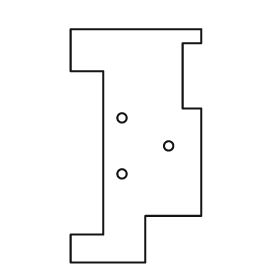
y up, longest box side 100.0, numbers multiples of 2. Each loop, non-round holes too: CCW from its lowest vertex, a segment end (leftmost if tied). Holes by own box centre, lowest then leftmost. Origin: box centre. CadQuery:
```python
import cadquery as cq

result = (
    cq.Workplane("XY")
    .moveTo(-28.0, -50.0)
    .lineTo(4.0, -50.0)
    .lineTo(4.0, -30.0)
    .lineTo(28.0, -30.0)
    .lineTo(28.0, 16.0)
    .lineTo(20.0, 16.0)
    .lineTo(20.0, 44.0)
    .lineTo(28.0, 44.0)
    .lineTo(28.0, 50.0)
    .lineTo(-28.0, 50.0)
    .lineTo(-28.0, 32.0)
    .lineTo(-14.0, 32.0)
    .lineTo(-14.0, -38.0)
    .lineTo(-28.0, -38.0)
    .close()
    .moveTo(-6.0, -12.0)
    .circle(2.0)
    .moveTo(14.0, 0.0)
    .circle(2.0)
    .moveTo(-6.0, 12.0)
    .circle(2.0)
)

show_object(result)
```